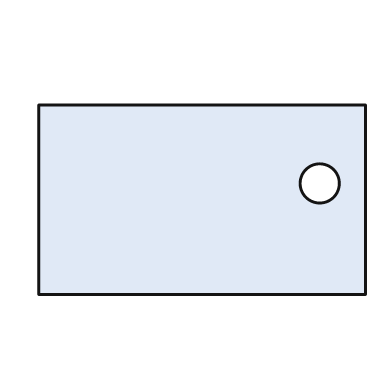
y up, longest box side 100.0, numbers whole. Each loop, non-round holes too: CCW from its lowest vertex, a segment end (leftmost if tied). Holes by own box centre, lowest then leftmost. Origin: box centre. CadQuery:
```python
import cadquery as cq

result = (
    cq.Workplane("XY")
    .moveTo(-50.0, -29.0)
    .lineTo(50.0, -29.0)
    .lineTo(50.0, 29.0)
    .lineTo(-50.0, 29.0)
    .close()
    .moveTo(36.0, 5.0)
    .circle(6.0)
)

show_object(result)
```